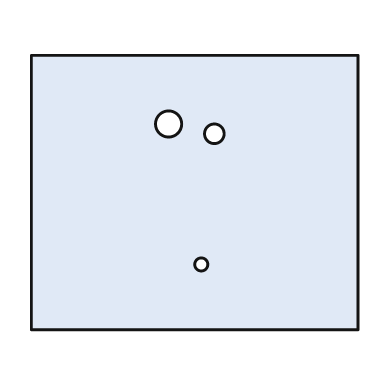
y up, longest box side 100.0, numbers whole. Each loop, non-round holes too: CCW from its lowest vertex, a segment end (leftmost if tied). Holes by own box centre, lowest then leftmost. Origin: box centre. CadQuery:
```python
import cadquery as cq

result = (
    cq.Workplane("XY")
    .moveTo(-50.0, -42.0)
    .lineTo(50.0, -42.0)
    .lineTo(50.0, 42.0)
    .lineTo(-50.0, 42.0)
    .close()
    .moveTo(2.0, -22.0)
    .circle(2.0)
    .moveTo(6.0, 18.0)
    .circle(3.0)
    .moveTo(-8.0, 21.0)
    .circle(4.0)
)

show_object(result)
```